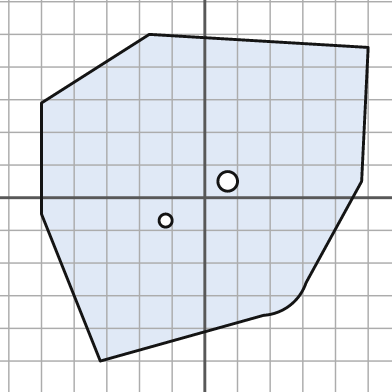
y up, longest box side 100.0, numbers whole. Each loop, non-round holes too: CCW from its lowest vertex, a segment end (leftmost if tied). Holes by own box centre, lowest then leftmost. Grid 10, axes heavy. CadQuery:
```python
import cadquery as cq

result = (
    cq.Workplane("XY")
    .moveTo(-32.0, -50.0)
    .lineTo(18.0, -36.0)
    .threePointArc((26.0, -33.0), (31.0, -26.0))
    .lineTo(48.0, 5.0)
    .lineTo(50.0, 46.0)
    .lineTo(-17.0, 50.0)
    .lineTo(-50.0, 29.0)
    .lineTo(-50.0, -5.0)
    .close()
    .moveTo(-12.0, -7.0)
    .circle(2.0)
    .moveTo(7.0, 5.0)
    .circle(3.0)
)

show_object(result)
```